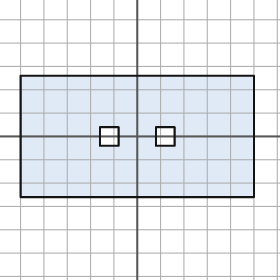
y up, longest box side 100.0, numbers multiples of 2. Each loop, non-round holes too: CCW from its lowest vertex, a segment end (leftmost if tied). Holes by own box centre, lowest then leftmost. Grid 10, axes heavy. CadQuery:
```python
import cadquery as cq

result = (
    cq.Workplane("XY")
    .moveTo(-50.0, -26.0)
    .lineTo(50.0, -26.0)
    .lineTo(50.0, 26.0)
    .lineTo(-50.0, 26.0)
    .close()
    .moveTo(-16.0, -4.0)
    .lineTo(-8.0, -4.0)
    .lineTo(-8.0, 4.0)
    .lineTo(-16.0, 4.0)
    .close()
    .moveTo(8.0, -4.0)
    .lineTo(16.0, -4.0)
    .lineTo(16.0, 4.0)
    .lineTo(8.0, 4.0)
    .close()
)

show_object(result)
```